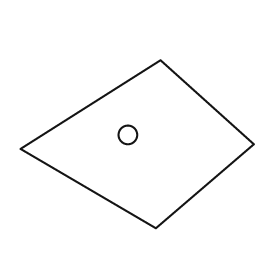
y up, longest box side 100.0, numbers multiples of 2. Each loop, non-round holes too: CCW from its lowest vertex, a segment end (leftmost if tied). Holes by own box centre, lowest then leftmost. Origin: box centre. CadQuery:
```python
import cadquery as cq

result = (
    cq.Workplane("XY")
    .moveTo(8.0, -36.0)
    .lineTo(50.0, 0.0)
    .lineTo(10.0, 36.0)
    .lineTo(-50.0, -2.0)
    .close()
    .moveTo(-4.0, 4.0)
    .circle(4.0)
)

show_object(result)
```